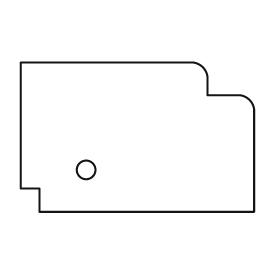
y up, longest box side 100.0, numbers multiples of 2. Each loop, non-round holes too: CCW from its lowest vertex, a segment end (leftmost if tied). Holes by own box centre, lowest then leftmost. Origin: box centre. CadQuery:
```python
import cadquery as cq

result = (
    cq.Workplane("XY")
    .moveTo(-42.0, -32.0)
    .lineTo(50.0, -32.0)
    .lineTo(50.0, 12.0)
    .threePointArc((48.0, 16.0), (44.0, 18.0))
    .lineTo(30.0, 18.0)
    .lineTo(30.0, 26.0)
    .threePointArc((28.0, 30.0), (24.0, 32.0))
    .lineTo(-50.0, 32.0)
    .lineTo(-50.0, -22.0)
    .lineTo(-42.0, -22.0)
    .close()
    .moveTo(-22.0, -14.0)
    .circle(4.0)
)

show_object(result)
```